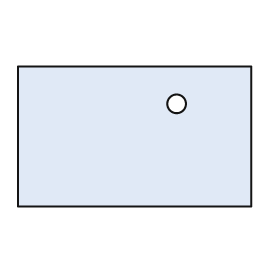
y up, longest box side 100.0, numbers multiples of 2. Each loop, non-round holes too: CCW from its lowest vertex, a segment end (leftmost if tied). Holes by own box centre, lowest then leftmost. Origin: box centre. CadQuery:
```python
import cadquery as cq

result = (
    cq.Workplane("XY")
    .moveTo(-50.0, -30.0)
    .lineTo(50.0, -30.0)
    .lineTo(50.0, 30.0)
    .lineTo(-50.0, 30.0)
    .close()
    .moveTo(18.0, 14.0)
    .circle(4.0)
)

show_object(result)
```